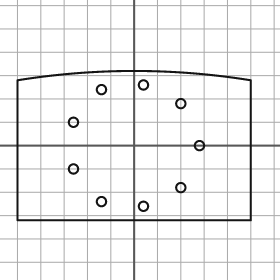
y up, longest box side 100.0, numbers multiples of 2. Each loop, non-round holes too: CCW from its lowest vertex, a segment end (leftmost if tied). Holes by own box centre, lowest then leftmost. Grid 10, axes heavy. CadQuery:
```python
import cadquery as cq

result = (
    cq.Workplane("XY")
    .moveTo(-50.0, -32.0)
    .lineTo(50.0, -32.0)
    .lineTo(50.0, 28.0)
    .threePointArc((0.0, 32.0), (-50.0, 28.0))
    .close()
    .moveTo(4.0, -26.0)
    .circle(2.0)
    .moveTo(-14.0, -24.0)
    .circle(2.0)
    .moveTo(20.0, -18.0)
    .circle(2.0)
    .moveTo(-26.0, -10.0)
    .circle(2.0)
    .moveTo(28.0, 0.0)
    .circle(2.0)
    .moveTo(-26.0, 10.0)
    .circle(2.0)
    .moveTo(20.0, 18.0)
    .circle(2.0)
    .moveTo(-14.0, 24.0)
    .circle(2.0)
    .moveTo(4.0, 26.0)
    .circle(2.0)
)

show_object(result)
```